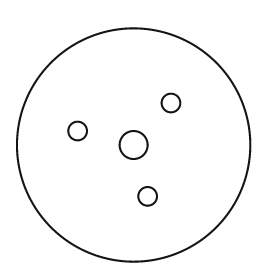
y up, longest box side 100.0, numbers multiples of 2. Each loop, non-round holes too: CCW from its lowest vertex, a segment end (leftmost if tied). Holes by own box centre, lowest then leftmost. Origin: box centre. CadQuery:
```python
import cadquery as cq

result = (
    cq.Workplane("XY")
    .moveTo(0.0, 0.0)
    .circle(50.0)
    .moveTo(6.0, -22.0)
    .circle(4.0)
    .moveTo(0.0, 0.0)
    .circle(6.0)
    .moveTo(-24.0, 6.0)
    .circle(4.0)
    .moveTo(16.0, 18.0)
    .circle(4.0)
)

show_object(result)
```